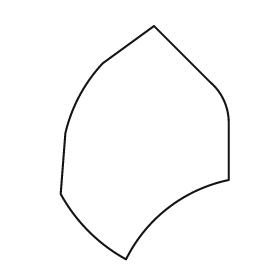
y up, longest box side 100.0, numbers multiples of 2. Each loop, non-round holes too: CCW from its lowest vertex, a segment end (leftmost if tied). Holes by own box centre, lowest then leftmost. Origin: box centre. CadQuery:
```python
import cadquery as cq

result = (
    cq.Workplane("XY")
    .moveTo(-8.0, -50.0)
    .threePointArc((10.0, -28.0), (36.0, -16.0))
    .lineTo(36.0, 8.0)
    .threePointArc((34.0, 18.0), (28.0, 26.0))
    .lineTo(4.0, 50.0)
    .lineTo(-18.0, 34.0)
    .threePointArc((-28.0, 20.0), (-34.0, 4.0))
    .lineTo(-36.0, -22.0)
    .threePointArc((-24.0, -38.0), (-8.0, -50.0))
    .close()
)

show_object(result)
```